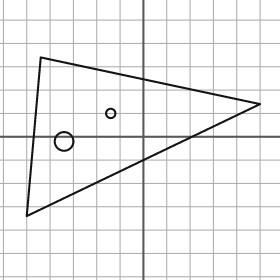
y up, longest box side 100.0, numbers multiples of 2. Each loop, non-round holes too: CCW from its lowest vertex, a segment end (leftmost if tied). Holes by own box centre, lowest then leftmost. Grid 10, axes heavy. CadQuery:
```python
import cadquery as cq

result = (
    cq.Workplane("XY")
    .moveTo(-50.0, -34.0)
    .lineTo(50.0, 14.0)
    .lineTo(-44.0, 34.0)
    .close()
    .moveTo(-34.0, -2.0)
    .circle(4.0)
    .moveTo(-14.0, 10.0)
    .circle(2.0)
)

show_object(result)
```